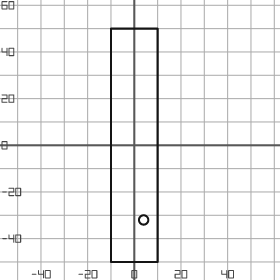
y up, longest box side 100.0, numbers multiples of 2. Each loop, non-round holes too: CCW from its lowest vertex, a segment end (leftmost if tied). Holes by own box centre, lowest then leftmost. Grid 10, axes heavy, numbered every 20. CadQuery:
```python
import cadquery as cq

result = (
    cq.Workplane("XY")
    .moveTo(-10.0, -50.0)
    .lineTo(10.0, -50.0)
    .lineTo(10.0, 50.0)
    .lineTo(-10.0, 50.0)
    .close()
    .moveTo(4.0, -32.0)
    .circle(2.0)
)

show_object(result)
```